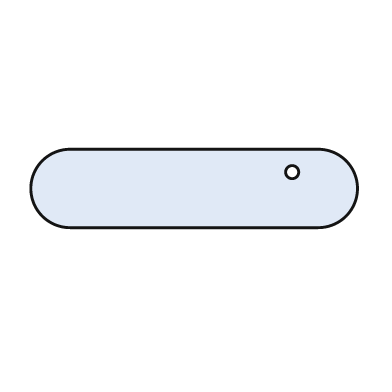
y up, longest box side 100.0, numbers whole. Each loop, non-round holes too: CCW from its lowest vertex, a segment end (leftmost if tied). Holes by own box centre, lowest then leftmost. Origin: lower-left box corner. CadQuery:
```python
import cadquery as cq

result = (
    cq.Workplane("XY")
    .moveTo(12.0, 0.0)
    .lineTo(88.0, 0.0)
    .threePointArc((100.0, 12.0), (88.0, 24.0))
    .lineTo(12.0, 24.0)
    .threePointArc((0.0, 12.0), (12.0, 0.0))
    .close()
    .moveTo(80.0, 17.0)
    .circle(2.0)
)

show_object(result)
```